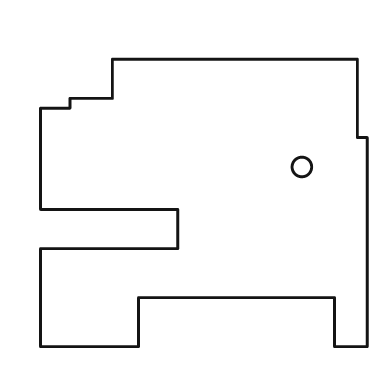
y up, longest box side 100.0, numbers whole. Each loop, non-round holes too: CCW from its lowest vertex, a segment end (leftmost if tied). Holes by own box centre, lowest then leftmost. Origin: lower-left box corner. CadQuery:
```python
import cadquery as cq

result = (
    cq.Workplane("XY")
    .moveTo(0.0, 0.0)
    .lineTo(30.0, 0.0)
    .lineTo(30.0, 15.0)
    .lineTo(90.0, 15.0)
    .lineTo(90.0, 0.0)
    .lineTo(100.0, 0.0)
    .lineTo(100.0, 64.0)
    .lineTo(97.0, 64.0)
    .lineTo(97.0, 88.0)
    .lineTo(22.0, 88.0)
    .lineTo(22.0, 76.0)
    .lineTo(9.0, 76.0)
    .lineTo(9.0, 73.0)
    .lineTo(0.0, 73.0)
    .lineTo(0.0, 42.0)
    .lineTo(42.0, 42.0)
    .lineTo(42.0, 30.0)
    .lineTo(0.0, 30.0)
    .close()
    .moveTo(80.0, 55.0)
    .circle(3.0)
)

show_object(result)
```